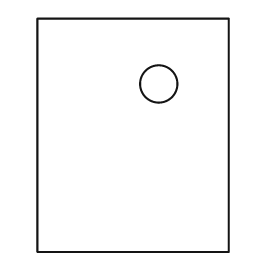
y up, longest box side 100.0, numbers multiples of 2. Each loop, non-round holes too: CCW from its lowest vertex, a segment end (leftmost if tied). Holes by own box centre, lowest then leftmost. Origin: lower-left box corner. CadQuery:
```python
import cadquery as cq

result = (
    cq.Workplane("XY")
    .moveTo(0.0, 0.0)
    .lineTo(82.0, 0.0)
    .lineTo(82.0, 100.0)
    .lineTo(0.0, 100.0)
    .close()
    .moveTo(52.0, 72.0)
    .circle(8.0)
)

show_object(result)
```